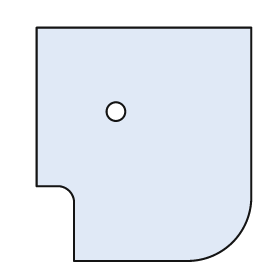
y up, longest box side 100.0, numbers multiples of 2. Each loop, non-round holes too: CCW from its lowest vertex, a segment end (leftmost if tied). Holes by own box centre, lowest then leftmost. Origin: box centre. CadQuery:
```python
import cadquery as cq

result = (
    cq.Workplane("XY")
    .moveTo(-30.0, -50.0)
    .lineTo(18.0, -50.0)
    .threePointArc((38.0, -42.0), (46.0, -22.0))
    .lineTo(46.0, 50.0)
    .lineTo(-46.0, 50.0)
    .lineTo(-46.0, -18.0)
    .lineTo(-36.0, -18.0)
    .threePointArc((-32.0, -20.0), (-30.0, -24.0))
    .close()
    .moveTo(-12.0, 14.0)
    .circle(4.0)
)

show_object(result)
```